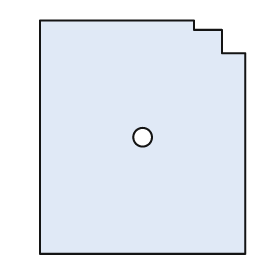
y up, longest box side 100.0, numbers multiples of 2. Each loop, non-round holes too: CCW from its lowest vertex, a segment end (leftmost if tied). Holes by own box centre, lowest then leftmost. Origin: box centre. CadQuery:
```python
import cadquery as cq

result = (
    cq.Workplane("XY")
    .moveTo(-44.0, -50.0)
    .lineTo(44.0, -50.0)
    .lineTo(44.0, 36.0)
    .lineTo(34.0, 36.0)
    .lineTo(34.0, 46.0)
    .lineTo(22.0, 46.0)
    .lineTo(22.0, 50.0)
    .lineTo(-44.0, 50.0)
    .close()
    .moveTo(0.0, 0.0)
    .circle(4.0)
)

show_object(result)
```